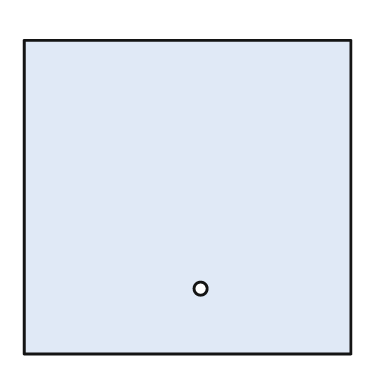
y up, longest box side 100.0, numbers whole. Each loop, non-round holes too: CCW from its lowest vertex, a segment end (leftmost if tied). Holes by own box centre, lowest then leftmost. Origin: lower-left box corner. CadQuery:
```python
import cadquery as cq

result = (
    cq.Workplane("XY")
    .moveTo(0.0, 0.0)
    .lineTo(100.0, 0.0)
    .lineTo(100.0, 96.0)
    .lineTo(0.0, 96.0)
    .close()
    .moveTo(54.0, 20.0)
    .circle(2.0)
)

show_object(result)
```